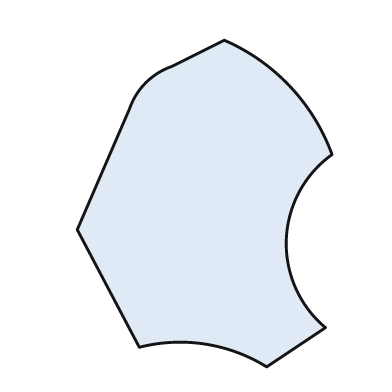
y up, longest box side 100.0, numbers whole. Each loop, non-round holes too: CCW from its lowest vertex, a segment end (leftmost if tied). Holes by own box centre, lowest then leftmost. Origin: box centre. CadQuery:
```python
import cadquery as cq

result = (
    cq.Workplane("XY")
    .moveTo(19.0, -50.0)
    .lineTo(37.0, -38.0)
    .threePointArc((25.0, -11.0), (39.0, 15.0))
    .threePointArc((26.0, 36.0), (6.0, 50.0))
    .lineTo(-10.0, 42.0)
    .threePointArc((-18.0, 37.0), (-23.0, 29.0))
    .lineTo(-39.0, -8.0)
    .lineTo(-20.0, -44.0)
    .threePointArc((0.0, -43.0), (19.0, -50.0))
    .close()
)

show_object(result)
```